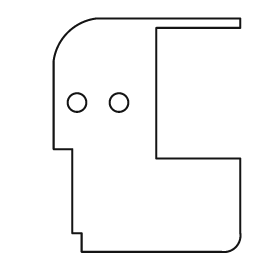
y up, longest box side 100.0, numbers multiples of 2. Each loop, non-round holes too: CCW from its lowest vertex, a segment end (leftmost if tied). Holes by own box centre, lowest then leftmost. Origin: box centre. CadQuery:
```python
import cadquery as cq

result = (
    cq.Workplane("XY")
    .moveTo(-28.0, -50.0)
    .lineTo(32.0, -50.0)
    .threePointArc((38.0, -48.0), (40.0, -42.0))
    .lineTo(40.0, -10.0)
    .lineTo(4.0, -10.0)
    .lineTo(4.0, 46.0)
    .lineTo(40.0, 46.0)
    .lineTo(40.0, 50.0)
    .lineTo(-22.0, 50.0)
    .threePointArc((-34.0, 44.0), (-40.0, 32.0))
    .lineTo(-40.0, -6.0)
    .lineTo(-32.0, -6.0)
    .lineTo(-32.0, -42.0)
    .lineTo(-28.0, -42.0)
    .close()
    .moveTo(-30.0, 14.0)
    .circle(4.0)
    .moveTo(-12.0, 14.0)
    .circle(4.0)
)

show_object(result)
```